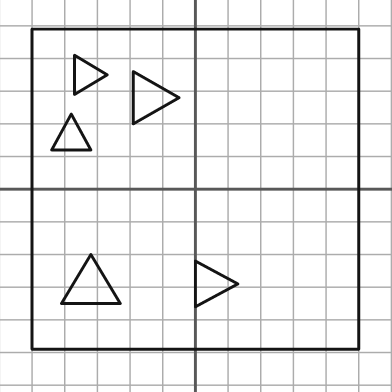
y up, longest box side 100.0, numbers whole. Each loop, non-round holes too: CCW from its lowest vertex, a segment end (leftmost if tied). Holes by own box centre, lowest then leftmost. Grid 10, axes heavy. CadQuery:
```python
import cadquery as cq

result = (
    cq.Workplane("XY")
    .moveTo(-50.0, -49.0)
    .lineTo(50.0, -49.0)
    .lineTo(50.0, 49.0)
    .lineTo(-50.0, 49.0)
    .close()
    .moveTo(0.0, -36.0)
    .lineTo(13.0, -29.0)
    .lineTo(0.0, -22.0)
    .close()
    .moveTo(-41.0, -35.0)
    .lineTo(-23.0, -35.0)
    .lineTo(-32.0, -20.0)
    .close()
    .moveTo(-44.0, 12.0)
    .lineTo(-32.0, 12.0)
    .lineTo(-38.0, 23.0)
    .close()
    .moveTo(-19.0, 20.0)
    .lineTo(-5.0, 28.0)
    .lineTo(-19.0, 36.0)
    .close()
    .moveTo(-37.0, 29.0)
    .lineTo(-27.0, 35.0)
    .lineTo(-37.0, 41.0)
    .close()
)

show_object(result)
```